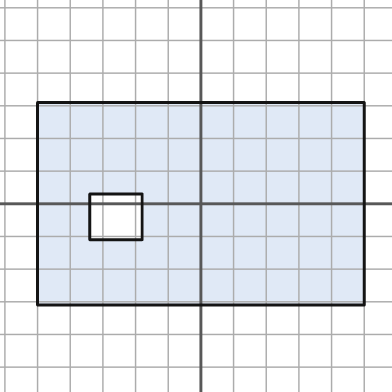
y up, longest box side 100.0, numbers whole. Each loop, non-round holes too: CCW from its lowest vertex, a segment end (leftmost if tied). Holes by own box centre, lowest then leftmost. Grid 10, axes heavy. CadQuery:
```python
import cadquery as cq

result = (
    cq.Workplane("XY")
    .moveTo(-50.0, -31.0)
    .lineTo(50.0, -31.0)
    .lineTo(50.0, 31.0)
    .lineTo(-50.0, 31.0)
    .close()
    .moveTo(-34.0, -11.0)
    .lineTo(-18.0, -11.0)
    .lineTo(-18.0, 3.0)
    .lineTo(-34.0, 3.0)
    .close()
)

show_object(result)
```